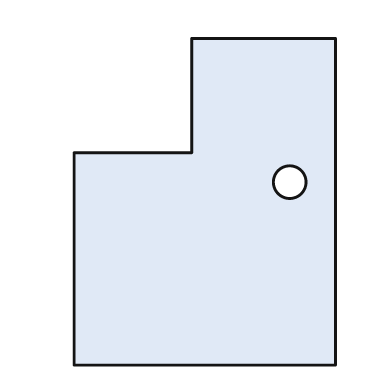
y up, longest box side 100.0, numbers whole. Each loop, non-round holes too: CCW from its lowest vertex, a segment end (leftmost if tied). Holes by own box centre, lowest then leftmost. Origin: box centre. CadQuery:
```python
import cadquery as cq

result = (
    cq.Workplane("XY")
    .moveTo(-40.0, -50.0)
    .lineTo(40.0, -50.0)
    .lineTo(40.0, 50.0)
    .lineTo(-4.0, 50.0)
    .lineTo(-4.0, 15.0)
    .lineTo(-40.0, 15.0)
    .close()
    .moveTo(26.0, 6.0)
    .circle(5.0)
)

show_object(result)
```